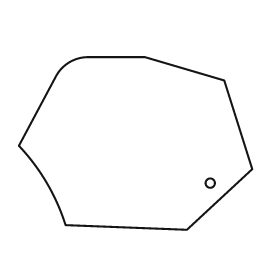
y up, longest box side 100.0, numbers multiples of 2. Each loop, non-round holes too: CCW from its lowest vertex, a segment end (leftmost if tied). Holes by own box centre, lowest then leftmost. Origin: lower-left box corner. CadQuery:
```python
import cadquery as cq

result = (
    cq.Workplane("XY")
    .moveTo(72.0, 0.0)
    .lineTo(100.0, 26.0)
    .lineTo(88.0, 64.0)
    .lineTo(54.0, 74.0)
    .lineTo(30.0, 74.0)
    .threePointArc((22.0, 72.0), (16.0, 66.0))
    .lineTo(0.0, 36.0)
    .threePointArc((12.0, 20.0), (20.0, 2.0))
    .close()
    .moveTo(82.0, 20.0)
    .circle(2.0)
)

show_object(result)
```